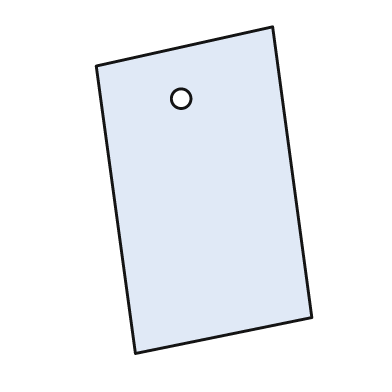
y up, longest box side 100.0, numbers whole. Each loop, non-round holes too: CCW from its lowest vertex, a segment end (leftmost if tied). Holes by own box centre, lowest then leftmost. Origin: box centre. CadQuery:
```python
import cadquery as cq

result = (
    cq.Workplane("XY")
    .moveTo(-21.0, -50.0)
    .lineTo(33.0, -39.0)
    .lineTo(21.0, 50.0)
    .lineTo(-33.0, 38.0)
    .close()
    .moveTo(-7.0, 28.0)
    .circle(3.0)
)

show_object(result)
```